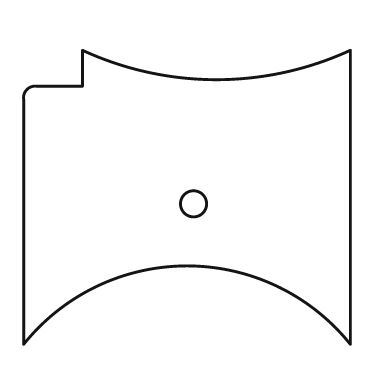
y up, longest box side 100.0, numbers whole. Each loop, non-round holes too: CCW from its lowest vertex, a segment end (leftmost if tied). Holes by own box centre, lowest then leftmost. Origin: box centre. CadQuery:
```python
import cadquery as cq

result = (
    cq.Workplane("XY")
    .moveTo(-50.0, -45.0)
    .threePointArc((0.0, -21.0), (50.0, -45.0))
    .lineTo(50.0, 45.0)
    .threePointArc((9.0, 36.0), (-32.0, 45.0))
    .lineTo(-32.0, 34.0)
    .lineTo(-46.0, 34.0)
    .threePointArc((-49.0, 33.0), (-50.0, 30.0))
    .close()
    .moveTo(2.0, -2.0)
    .circle(4.0)
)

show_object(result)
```